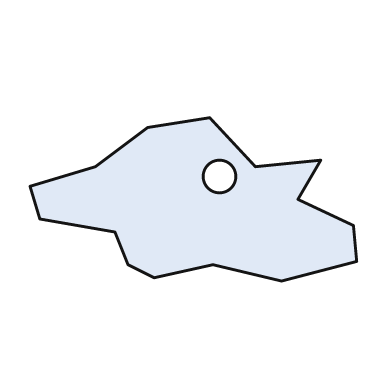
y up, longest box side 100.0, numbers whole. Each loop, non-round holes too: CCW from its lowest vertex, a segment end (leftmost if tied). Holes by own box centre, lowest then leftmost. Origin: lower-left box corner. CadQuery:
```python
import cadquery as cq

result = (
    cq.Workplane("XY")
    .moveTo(77.0, 0.0)
    .lineTo(100.0, 6.0)
    .lineTo(99.0, 17.0)
    .lineTo(82.0, 25.0)
    .lineTo(89.0, 37.0)
    .lineTo(69.0, 35.0)
    .lineTo(55.0, 50.0)
    .lineTo(36.0, 47.0)
    .lineTo(20.0, 35.0)
    .lineTo(0.0, 29.0)
    .lineTo(3.0, 19.0)
    .lineTo(26.0, 15.0)
    .lineTo(30.0, 5.0)
    .lineTo(38.0, 1.0)
    .lineTo(56.0, 5.0)
    .close()
    .moveTo(58.0, 32.0)
    .circle(5.0)
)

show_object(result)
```